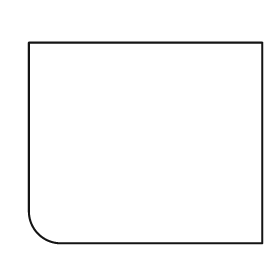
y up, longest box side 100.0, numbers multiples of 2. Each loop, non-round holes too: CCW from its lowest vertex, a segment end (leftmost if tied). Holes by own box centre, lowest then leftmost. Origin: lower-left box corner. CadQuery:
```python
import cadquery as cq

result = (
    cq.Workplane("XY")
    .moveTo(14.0, 0.0)
    .lineTo(100.0, 0.0)
    .lineTo(100.0, 86.0)
    .lineTo(0.0, 86.0)
    .lineTo(0.0, 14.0)
    .threePointArc((4.0, 4.0), (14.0, 0.0))
    .close()
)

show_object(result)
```